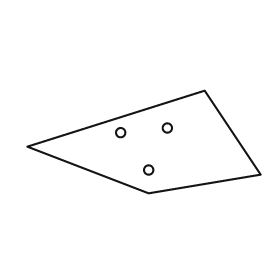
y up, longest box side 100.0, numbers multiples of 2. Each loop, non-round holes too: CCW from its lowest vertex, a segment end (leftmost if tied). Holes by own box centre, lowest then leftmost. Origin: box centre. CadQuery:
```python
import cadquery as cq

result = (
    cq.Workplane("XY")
    .moveTo(2.0, -22.0)
    .lineTo(50.0, -14.0)
    .lineTo(26.0, 22.0)
    .lineTo(-50.0, -2.0)
    .close()
    .moveTo(2.0, -12.0)
    .circle(2.0)
    .moveTo(-10.0, 4.0)
    .circle(2.0)
    .moveTo(10.0, 6.0)
    .circle(2.0)
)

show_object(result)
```